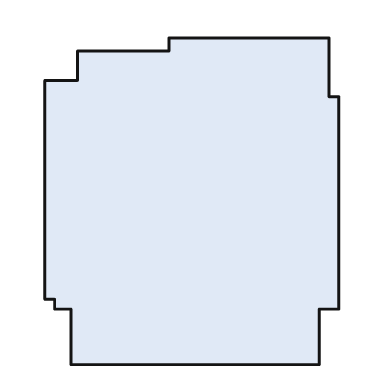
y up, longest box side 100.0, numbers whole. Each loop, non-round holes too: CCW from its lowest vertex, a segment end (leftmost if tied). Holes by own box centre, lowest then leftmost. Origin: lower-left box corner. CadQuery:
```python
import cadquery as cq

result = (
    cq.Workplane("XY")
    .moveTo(8.0, 0.0)
    .lineTo(84.0, 0.0)
    .lineTo(84.0, 17.0)
    .lineTo(90.0, 17.0)
    .lineTo(90.0, 82.0)
    .lineTo(87.0, 82.0)
    .lineTo(87.0, 100.0)
    .lineTo(38.0, 100.0)
    .lineTo(38.0, 96.0)
    .lineTo(10.0, 96.0)
    .lineTo(10.0, 87.0)
    .lineTo(0.0, 87.0)
    .lineTo(0.0, 20.0)
    .lineTo(3.0, 20.0)
    .lineTo(3.0, 17.0)
    .lineTo(8.0, 17.0)
    .close()
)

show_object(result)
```